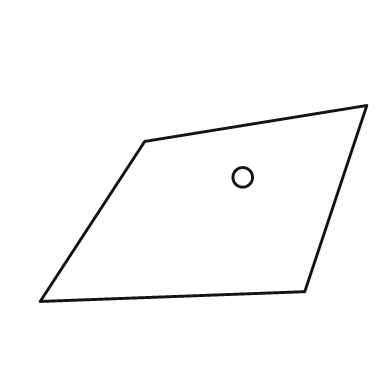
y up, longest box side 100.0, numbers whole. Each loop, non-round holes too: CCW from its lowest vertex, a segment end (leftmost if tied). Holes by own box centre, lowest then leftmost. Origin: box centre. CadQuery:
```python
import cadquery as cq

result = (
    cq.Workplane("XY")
    .moveTo(-50.0, -30.0)
    .lineTo(31.0, -27.0)
    .lineTo(50.0, 30.0)
    .lineTo(-18.0, 19.0)
    .close()
    .moveTo(12.0, 8.0)
    .circle(3.0)
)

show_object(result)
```